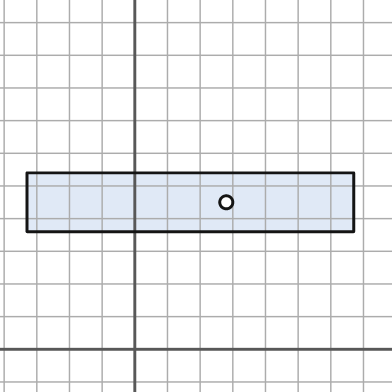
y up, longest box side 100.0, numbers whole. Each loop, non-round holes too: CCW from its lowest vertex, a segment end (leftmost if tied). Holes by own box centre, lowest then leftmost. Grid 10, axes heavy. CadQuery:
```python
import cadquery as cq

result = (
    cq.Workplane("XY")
    .moveTo(-33.0, 36.0)
    .lineTo(67.0, 36.0)
    .lineTo(67.0, 54.0)
    .lineTo(-33.0, 54.0)
    .close()
    .moveTo(28.0, 45.0)
    .circle(2.0)
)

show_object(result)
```